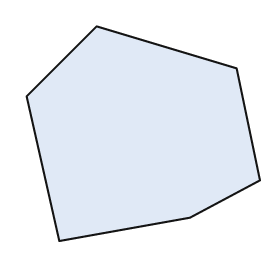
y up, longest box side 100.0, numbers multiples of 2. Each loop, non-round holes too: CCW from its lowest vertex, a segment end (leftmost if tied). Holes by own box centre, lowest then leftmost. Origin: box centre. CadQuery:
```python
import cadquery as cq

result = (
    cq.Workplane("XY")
    .moveTo(-36.0, -46.0)
    .lineTo(20.0, -36.0)
    .lineTo(50.0, -20.0)
    .lineTo(40.0, 28.0)
    .lineTo(-20.0, 46.0)
    .lineTo(-50.0, 16.0)
    .close()
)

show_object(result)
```